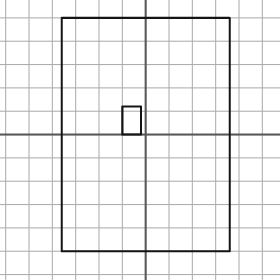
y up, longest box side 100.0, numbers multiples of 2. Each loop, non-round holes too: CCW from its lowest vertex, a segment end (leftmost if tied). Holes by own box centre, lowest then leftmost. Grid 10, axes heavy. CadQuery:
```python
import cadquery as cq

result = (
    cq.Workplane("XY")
    .moveTo(-36.0, -50.0)
    .lineTo(36.0, -50.0)
    .lineTo(36.0, 50.0)
    .lineTo(-36.0, 50.0)
    .close()
    .moveTo(-10.0, 0.0)
    .lineTo(-2.0, 0.0)
    .lineTo(-2.0, 12.0)
    .lineTo(-10.0, 12.0)
    .close()
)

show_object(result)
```